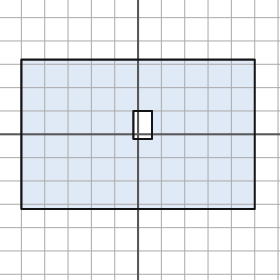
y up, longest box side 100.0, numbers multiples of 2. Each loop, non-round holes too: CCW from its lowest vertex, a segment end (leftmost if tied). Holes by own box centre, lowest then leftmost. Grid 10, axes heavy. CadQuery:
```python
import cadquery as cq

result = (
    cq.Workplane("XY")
    .moveTo(-50.0, -32.0)
    .lineTo(50.0, -32.0)
    .lineTo(50.0, 32.0)
    .lineTo(-50.0, 32.0)
    .close()
    .moveTo(-2.0, -2.0)
    .lineTo(6.0, -2.0)
    .lineTo(6.0, 10.0)
    .lineTo(-2.0, 10.0)
    .close()
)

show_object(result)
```